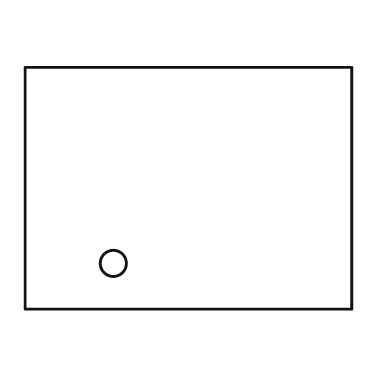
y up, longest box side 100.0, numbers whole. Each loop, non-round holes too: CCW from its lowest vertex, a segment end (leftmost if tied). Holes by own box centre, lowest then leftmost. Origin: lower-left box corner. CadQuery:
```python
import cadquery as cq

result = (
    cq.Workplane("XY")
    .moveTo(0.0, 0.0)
    .lineTo(100.0, 0.0)
    .lineTo(100.0, 74.0)
    .lineTo(0.0, 74.0)
    .close()
    .moveTo(27.0, 14.0)
    .circle(4.0)
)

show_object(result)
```